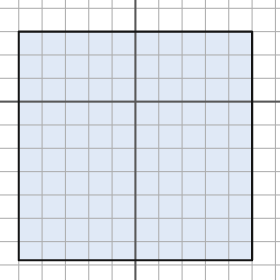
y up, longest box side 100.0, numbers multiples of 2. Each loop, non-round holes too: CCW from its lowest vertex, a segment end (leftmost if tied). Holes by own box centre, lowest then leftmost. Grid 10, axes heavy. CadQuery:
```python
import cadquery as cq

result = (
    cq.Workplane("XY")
    .moveTo(-50.0, -68.0)
    .lineTo(50.0, -68.0)
    .lineTo(50.0, 30.0)
    .lineTo(-50.0, 30.0)
    .close()
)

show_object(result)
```